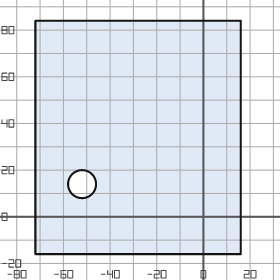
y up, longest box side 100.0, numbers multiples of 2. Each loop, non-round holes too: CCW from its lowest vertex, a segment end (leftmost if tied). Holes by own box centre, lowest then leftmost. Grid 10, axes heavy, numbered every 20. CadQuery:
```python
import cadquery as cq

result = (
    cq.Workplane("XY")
    .moveTo(-72.0, -16.0)
    .lineTo(16.0, -16.0)
    .lineTo(16.0, 84.0)
    .lineTo(-72.0, 84.0)
    .close()
    .moveTo(-52.0, 14.0)
    .circle(6.0)
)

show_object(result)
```